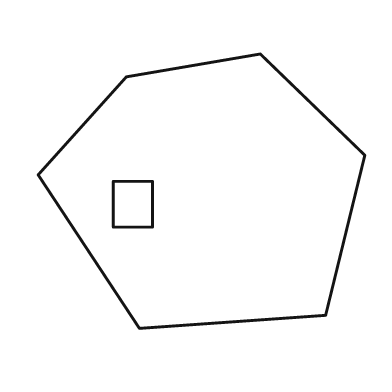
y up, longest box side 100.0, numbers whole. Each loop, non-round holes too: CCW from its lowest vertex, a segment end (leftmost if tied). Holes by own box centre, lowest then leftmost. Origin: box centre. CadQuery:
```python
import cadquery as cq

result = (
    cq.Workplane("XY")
    .moveTo(-19.0, -42.0)
    .lineTo(38.0, -38.0)
    .lineTo(50.0, 11.0)
    .lineTo(18.0, 42.0)
    .lineTo(-23.0, 35.0)
    .lineTo(-50.0, 5.0)
    .close()
    .moveTo(-27.0, -11.0)
    .lineTo(-15.0, -11.0)
    .lineTo(-15.0, 3.0)
    .lineTo(-27.0, 3.0)
    .close()
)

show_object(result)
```